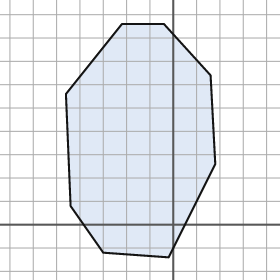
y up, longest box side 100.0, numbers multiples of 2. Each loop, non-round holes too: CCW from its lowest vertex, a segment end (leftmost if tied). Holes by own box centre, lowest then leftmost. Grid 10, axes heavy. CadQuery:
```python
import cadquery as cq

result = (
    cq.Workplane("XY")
    .moveTo(-2.0, -14.0)
    .lineTo(18.0, 26.0)
    .lineTo(16.0, 64.0)
    .lineTo(-4.0, 86.0)
    .lineTo(-22.0, 86.0)
    .lineTo(-46.0, 56.0)
    .lineTo(-44.0, 8.0)
    .lineTo(-30.0, -12.0)
    .close()
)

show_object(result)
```